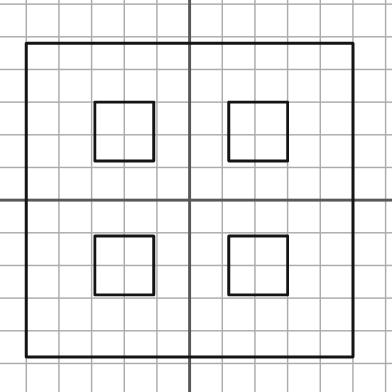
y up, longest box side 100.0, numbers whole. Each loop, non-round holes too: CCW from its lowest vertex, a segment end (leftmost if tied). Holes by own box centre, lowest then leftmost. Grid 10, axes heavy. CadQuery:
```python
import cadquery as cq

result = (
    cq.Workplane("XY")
    .moveTo(-50.0, -48.0)
    .lineTo(50.0, -48.0)
    .lineTo(50.0, 48.0)
    .lineTo(-50.0, 48.0)
    .close()
    .moveTo(-29.0, -29.0)
    .lineTo(-11.0, -29.0)
    .lineTo(-11.0, -11.0)
    .lineTo(-29.0, -11.0)
    .close()
    .moveTo(12.0, -29.0)
    .lineTo(30.0, -29.0)
    .lineTo(30.0, -11.0)
    .lineTo(12.0, -11.0)
    .close()
    .moveTo(-29.0, 12.0)
    .lineTo(-11.0, 12.0)
    .lineTo(-11.0, 30.0)
    .lineTo(-29.0, 30.0)
    .close()
    .moveTo(12.0, 12.0)
    .lineTo(30.0, 12.0)
    .lineTo(30.0, 30.0)
    .lineTo(12.0, 30.0)
    .close()
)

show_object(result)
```